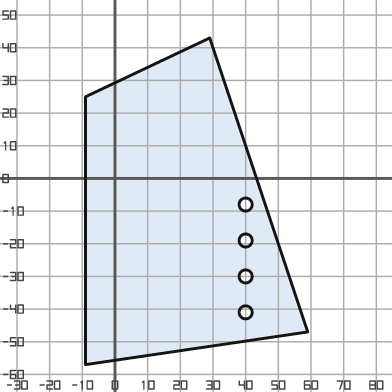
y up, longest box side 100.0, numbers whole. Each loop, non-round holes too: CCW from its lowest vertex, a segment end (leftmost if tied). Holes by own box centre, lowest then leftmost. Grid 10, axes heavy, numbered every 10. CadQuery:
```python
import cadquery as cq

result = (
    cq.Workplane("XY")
    .moveTo(-9.0, -57.0)
    .lineTo(59.0, -47.0)
    .lineTo(29.0, 43.0)
    .lineTo(-9.0, 25.0)
    .close()
    .moveTo(40.0, -41.0)
    .circle(2.0)
    .moveTo(40.0, -30.0)
    .circle(2.0)
    .moveTo(40.0, -19.0)
    .circle(2.0)
    .moveTo(40.0, -8.0)
    .circle(2.0)
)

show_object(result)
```